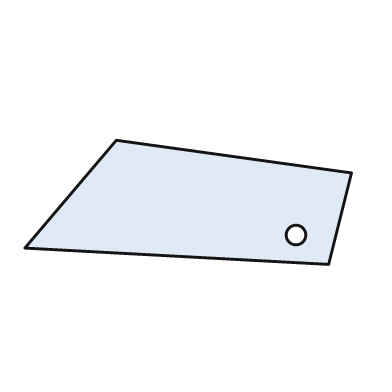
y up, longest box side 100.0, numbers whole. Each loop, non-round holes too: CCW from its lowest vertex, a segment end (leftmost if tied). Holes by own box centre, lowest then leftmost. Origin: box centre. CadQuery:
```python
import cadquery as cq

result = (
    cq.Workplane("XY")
    .moveTo(43.0, -19.0)
    .lineTo(50.0, 9.0)
    .lineTo(-22.0, 19.0)
    .lineTo(-50.0, -14.0)
    .close()
    .moveTo(33.0, -10.0)
    .circle(3.0)
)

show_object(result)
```